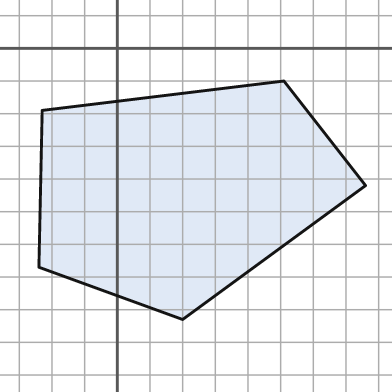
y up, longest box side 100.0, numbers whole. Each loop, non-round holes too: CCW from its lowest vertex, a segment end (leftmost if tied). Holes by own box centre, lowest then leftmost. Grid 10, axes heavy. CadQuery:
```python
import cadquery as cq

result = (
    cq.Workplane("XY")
    .moveTo(20.0, -83.0)
    .lineTo(76.0, -42.0)
    .lineTo(51.0, -10.0)
    .lineTo(-23.0, -19.0)
    .lineTo(-24.0, -67.0)
    .close()
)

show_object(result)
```